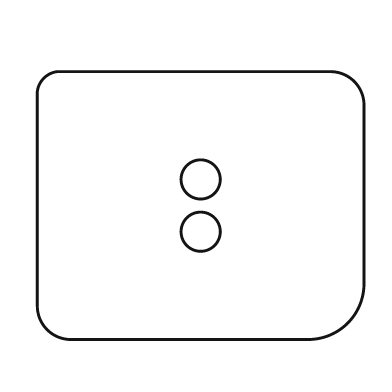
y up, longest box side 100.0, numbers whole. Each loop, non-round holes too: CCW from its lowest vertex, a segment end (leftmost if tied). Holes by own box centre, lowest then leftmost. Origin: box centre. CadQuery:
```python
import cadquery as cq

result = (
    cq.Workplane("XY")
    .moveTo(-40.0, -41.0)
    .lineTo(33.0, -41.0)
    .threePointArc((45.0, -36.0), (50.0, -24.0))
    .lineTo(50.0, 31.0)
    .threePointArc((47.0, 38.0), (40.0, 41.0))
    .lineTo(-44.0, 41.0)
    .threePointArc((-48.0, 39.0), (-50.0, 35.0))
    .lineTo(-50.0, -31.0)
    .threePointArc((-47.0, -38.0), (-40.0, -41.0))
    .close()
    .moveTo(0.0, -8.0)
    .circle(6.0)
    .moveTo(0.0, 8.0)
    .circle(6.0)
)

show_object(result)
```